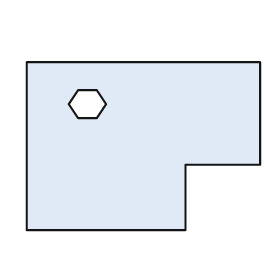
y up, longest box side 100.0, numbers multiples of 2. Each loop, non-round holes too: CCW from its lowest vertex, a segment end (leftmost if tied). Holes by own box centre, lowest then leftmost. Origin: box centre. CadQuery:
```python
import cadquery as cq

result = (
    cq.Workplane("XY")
    .moveTo(-50.0, -36.0)
    .lineTo(18.0, -36.0)
    .lineTo(18.0, -8.0)
    .lineTo(50.0, -8.0)
    .lineTo(50.0, 36.0)
    .lineTo(-50.0, 36.0)
    .close()
    .moveTo(-28.0, 12.0)
    .lineTo(-20.0, 12.0)
    .lineTo(-16.0, 18.0)
    .lineTo(-20.0, 24.0)
    .lineTo(-28.0, 24.0)
    .lineTo(-32.0, 18.0)
    .close()
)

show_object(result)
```